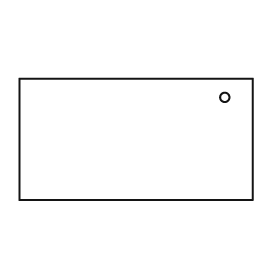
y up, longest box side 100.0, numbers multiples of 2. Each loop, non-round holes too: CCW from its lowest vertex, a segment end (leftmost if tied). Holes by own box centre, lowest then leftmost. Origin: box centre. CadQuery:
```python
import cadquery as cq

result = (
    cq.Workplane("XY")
    .moveTo(-50.0, -26.0)
    .lineTo(50.0, -26.0)
    .lineTo(50.0, 26.0)
    .lineTo(-50.0, 26.0)
    .close()
    .moveTo(38.0, 18.0)
    .circle(2.0)
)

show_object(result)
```